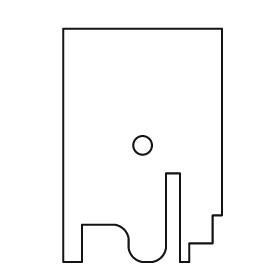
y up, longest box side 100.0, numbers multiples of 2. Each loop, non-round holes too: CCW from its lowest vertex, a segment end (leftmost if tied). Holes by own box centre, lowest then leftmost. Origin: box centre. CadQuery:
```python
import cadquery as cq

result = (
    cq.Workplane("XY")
    .moveTo(-34.0, -50.0)
    .lineTo(-26.0, -50.0)
    .lineTo(-26.0, -34.0)
    .lineTo(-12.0, -34.0)
    .threePointArc((-8.0, -36.0), (-6.0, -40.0))
    .lineTo(-6.0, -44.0)
    .threePointArc((-4.0, -48.0), (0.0, -50.0))
    .lineTo(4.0, -50.0)
    .threePointArc((8.0, -48.0), (10.0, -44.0))
    .lineTo(10.0, -12.0)
    .lineTo(16.0, -12.0)
    .lineTo(16.0, -50.0)
    .lineTo(20.0, -50.0)
    .lineTo(20.0, -42.0)
    .lineTo(30.0, -42.0)
    .lineTo(30.0, -30.0)
    .lineTo(34.0, -30.0)
    .lineTo(34.0, 50.0)
    .lineTo(-34.0, 50.0)
    .close()
    .moveTo(0.0, 0.0)
    .circle(4.0)
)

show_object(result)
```